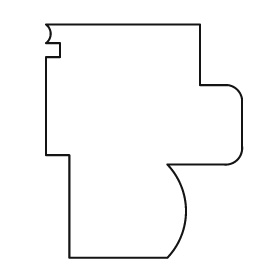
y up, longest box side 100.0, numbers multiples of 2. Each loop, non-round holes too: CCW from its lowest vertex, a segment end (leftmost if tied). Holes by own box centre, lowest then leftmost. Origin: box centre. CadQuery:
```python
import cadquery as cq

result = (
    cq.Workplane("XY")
    .moveTo(-32.0, -50.0)
    .lineTo(10.0, -50.0)
    .threePointArc((18.0, -30.0), (10.0, -10.0))
    .lineTo(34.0, -10.0)
    .threePointArc((40.0, -8.0), (42.0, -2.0))
    .lineTo(42.0, 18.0)
    .threePointArc((40.0, 22.0), (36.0, 24.0))
    .lineTo(24.0, 24.0)
    .lineTo(24.0, 50.0)
    .lineTo(-42.0, 50.0)
    .threePointArc((-40.0, 46.0), (-42.0, 42.0))
    .lineTo(-36.0, 42.0)
    .lineTo(-36.0, 36.0)
    .lineTo(-42.0, 36.0)
    .lineTo(-42.0, -6.0)
    .lineTo(-32.0, -6.0)
    .close()
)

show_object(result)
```